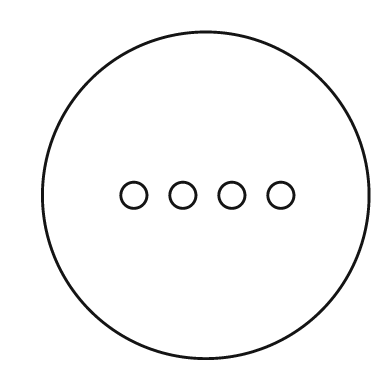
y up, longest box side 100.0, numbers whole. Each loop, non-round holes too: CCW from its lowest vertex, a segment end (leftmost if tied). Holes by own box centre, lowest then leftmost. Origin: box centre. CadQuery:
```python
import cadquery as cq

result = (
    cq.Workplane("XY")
    .moveTo(0.0, 0.0)
    .circle(50.0)
    .moveTo(-22.0, 0.0)
    .circle(4.0)
    .moveTo(-7.0, 0.0)
    .circle(4.0)
    .moveTo(8.0, 0.0)
    .circle(4.0)
    .moveTo(23.0, 0.0)
    .circle(4.0)
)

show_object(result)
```